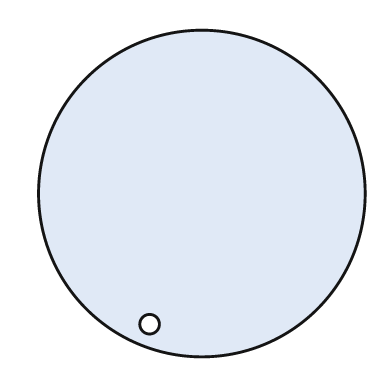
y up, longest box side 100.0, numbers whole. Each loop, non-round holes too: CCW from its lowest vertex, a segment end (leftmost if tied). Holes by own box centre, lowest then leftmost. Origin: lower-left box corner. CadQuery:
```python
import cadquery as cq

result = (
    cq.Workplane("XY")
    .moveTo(50.0, 50.0)
    .circle(50.0)
    .moveTo(34.0, 10.0)
    .circle(3.0)
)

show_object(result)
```